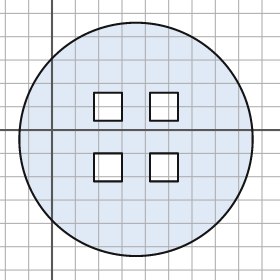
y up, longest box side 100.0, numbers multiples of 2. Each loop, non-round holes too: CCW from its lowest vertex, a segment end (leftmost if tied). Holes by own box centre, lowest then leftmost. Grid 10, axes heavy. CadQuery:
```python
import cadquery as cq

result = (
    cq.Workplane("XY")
    .moveTo(36.0, -4.0)
    .circle(50.0)
    .moveTo(18.0, -22.0)
    .lineTo(30.0, -22.0)
    .lineTo(30.0, -10.0)
    .lineTo(18.0, -10.0)
    .close()
    .moveTo(42.0, -22.0)
    .lineTo(54.0, -22.0)
    .lineTo(54.0, -10.0)
    .lineTo(42.0, -10.0)
    .close()
    .moveTo(18.0, 4.0)
    .lineTo(30.0, 4.0)
    .lineTo(30.0, 16.0)
    .lineTo(18.0, 16.0)
    .close()
    .moveTo(42.0, 4.0)
    .lineTo(54.0, 4.0)
    .lineTo(54.0, 16.0)
    .lineTo(42.0, 16.0)
    .close()
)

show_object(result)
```